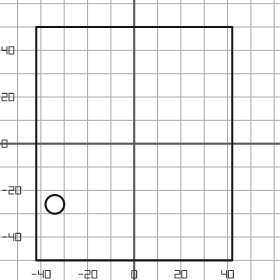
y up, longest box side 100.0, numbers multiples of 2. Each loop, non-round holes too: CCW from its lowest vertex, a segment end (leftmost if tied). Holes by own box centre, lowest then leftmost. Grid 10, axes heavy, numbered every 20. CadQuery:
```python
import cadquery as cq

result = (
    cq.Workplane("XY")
    .moveTo(-42.0, -50.0)
    .lineTo(42.0, -50.0)
    .lineTo(42.0, 50.0)
    .lineTo(-42.0, 50.0)
    .close()
    .moveTo(-34.0, -26.0)
    .circle(4.0)
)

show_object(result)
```